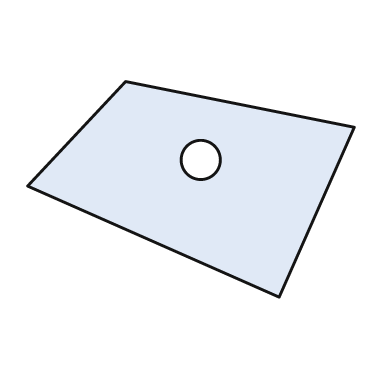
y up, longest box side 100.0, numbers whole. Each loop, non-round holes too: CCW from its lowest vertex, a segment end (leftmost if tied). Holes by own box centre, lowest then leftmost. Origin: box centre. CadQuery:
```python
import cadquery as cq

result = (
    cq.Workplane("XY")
    .moveTo(27.0, -33.0)
    .lineTo(50.0, 19.0)
    .lineTo(-20.0, 33.0)
    .lineTo(-50.0, 1.0)
    .close()
    .moveTo(3.0, 9.0)
    .circle(6.0)
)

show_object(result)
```